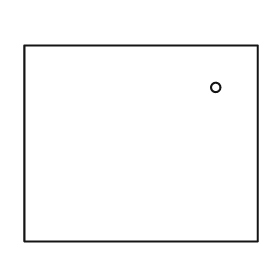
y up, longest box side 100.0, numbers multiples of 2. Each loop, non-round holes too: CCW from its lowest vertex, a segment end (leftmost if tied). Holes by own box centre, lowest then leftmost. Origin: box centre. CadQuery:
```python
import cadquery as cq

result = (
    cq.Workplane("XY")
    .moveTo(-50.0, -42.0)
    .lineTo(50.0, -42.0)
    .lineTo(50.0, 42.0)
    .lineTo(-50.0, 42.0)
    .close()
    .moveTo(32.0, 24.0)
    .circle(2.0)
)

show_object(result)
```